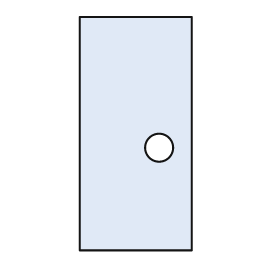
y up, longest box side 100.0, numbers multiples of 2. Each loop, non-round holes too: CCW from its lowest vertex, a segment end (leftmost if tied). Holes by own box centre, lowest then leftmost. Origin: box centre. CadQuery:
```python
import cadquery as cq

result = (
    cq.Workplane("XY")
    .moveTo(-24.0, -50.0)
    .lineTo(24.0, -50.0)
    .lineTo(24.0, 50.0)
    .lineTo(-24.0, 50.0)
    .close()
    .moveTo(10.0, -6.0)
    .circle(6.0)
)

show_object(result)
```